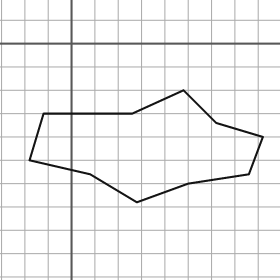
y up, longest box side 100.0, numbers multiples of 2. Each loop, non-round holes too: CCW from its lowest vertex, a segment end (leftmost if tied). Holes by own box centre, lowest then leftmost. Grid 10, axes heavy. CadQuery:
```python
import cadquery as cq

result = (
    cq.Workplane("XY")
    .moveTo(28.0, -68.0)
    .lineTo(50.0, -60.0)
    .lineTo(76.0, -56.0)
    .lineTo(82.0, -40.0)
    .lineTo(62.0, -34.0)
    .lineTo(48.0, -20.0)
    .lineTo(26.0, -30.0)
    .lineTo(-12.0, -30.0)
    .lineTo(-18.0, -50.0)
    .lineTo(8.0, -56.0)
    .close()
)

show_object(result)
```